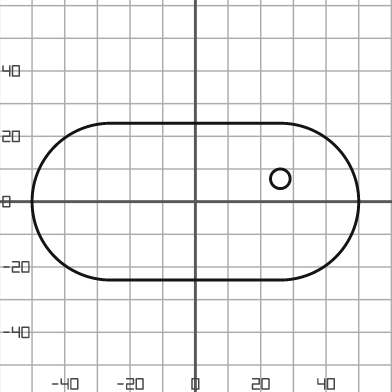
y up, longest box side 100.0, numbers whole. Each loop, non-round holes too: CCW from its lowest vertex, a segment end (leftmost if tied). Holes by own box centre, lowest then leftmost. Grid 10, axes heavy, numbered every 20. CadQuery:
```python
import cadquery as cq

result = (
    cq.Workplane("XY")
    .moveTo(-26.0, -24.0)
    .lineTo(26.0, -24.0)
    .threePointArc((50.0, 0.0), (26.0, 24.0))
    .lineTo(-26.0, 24.0)
    .threePointArc((-50.0, 0.0), (-26.0, -24.0))
    .close()
    .moveTo(26.0, 7.0)
    .circle(3.0)
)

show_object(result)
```